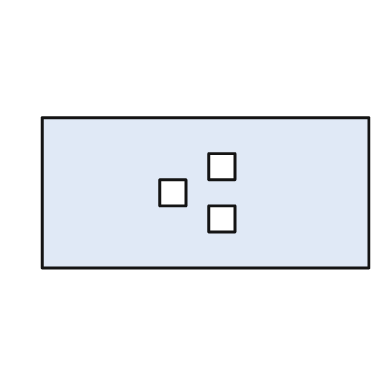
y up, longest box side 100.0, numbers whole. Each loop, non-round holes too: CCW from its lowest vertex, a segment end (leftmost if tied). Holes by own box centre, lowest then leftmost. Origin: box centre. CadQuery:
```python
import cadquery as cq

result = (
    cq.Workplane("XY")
    .moveTo(-50.0, -23.0)
    .lineTo(50.0, -23.0)
    .lineTo(50.0, 23.0)
    .lineTo(-50.0, 23.0)
    .close()
    .moveTo(1.0, -12.0)
    .lineTo(9.0, -12.0)
    .lineTo(9.0, -4.0)
    .lineTo(1.0, -4.0)
    .close()
    .moveTo(-14.0, -4.0)
    .lineTo(-6.0, -4.0)
    .lineTo(-6.0, 4.0)
    .lineTo(-14.0, 4.0)
    .close()
    .moveTo(1.0, 4.0)
    .lineTo(9.0, 4.0)
    .lineTo(9.0, 12.0)
    .lineTo(1.0, 12.0)
    .close()
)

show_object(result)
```